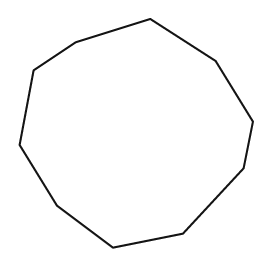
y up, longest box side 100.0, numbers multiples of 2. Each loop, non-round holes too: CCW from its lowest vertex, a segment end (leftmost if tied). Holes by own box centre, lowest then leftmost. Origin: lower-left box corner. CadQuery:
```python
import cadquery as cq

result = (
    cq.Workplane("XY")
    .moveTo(40.0, 0.0)
    .lineTo(70.0, 6.0)
    .lineTo(96.0, 34.0)
    .lineTo(100.0, 54.0)
    .lineTo(84.0, 80.0)
    .lineTo(56.0, 98.0)
    .lineTo(24.0, 88.0)
    .lineTo(6.0, 76.0)
    .lineTo(0.0, 44.0)
    .lineTo(16.0, 18.0)
    .close()
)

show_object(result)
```